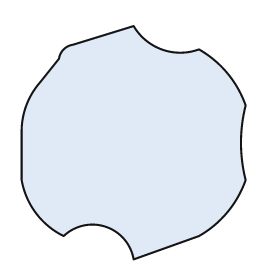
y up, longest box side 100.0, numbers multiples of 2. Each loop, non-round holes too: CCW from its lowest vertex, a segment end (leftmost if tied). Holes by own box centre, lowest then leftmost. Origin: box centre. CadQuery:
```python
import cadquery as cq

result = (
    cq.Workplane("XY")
    .moveTo(0.0, -50.0)
    .lineTo(28.0, -40.0)
    .threePointArc((40.0, -30.0), (48.0, -16.0))
    .threePointArc((46.0, 0.0), (48.0, 16.0))
    .threePointArc((40.0, 30.0), (28.0, 40.0))
    .threePointArc((12.0, 40.0), (0.0, 50.0))
    .lineTo(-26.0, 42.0)
    .threePointArc((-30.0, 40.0), (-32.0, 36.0))
    .lineTo(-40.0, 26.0)
    .threePointArc((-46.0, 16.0), (-48.0, 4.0))
    .lineTo(-48.0, -16.0)
    .threePointArc((-42.0, -30.0), (-30.0, -40.0))
    .threePointArc((-12.0, -36.0), (0.0, -50.0))
    .close()
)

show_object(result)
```